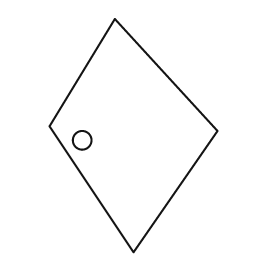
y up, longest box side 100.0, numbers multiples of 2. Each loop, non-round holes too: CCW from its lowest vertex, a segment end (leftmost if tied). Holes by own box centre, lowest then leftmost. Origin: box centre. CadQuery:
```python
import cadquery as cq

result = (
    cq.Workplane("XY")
    .moveTo(0.0, -50.0)
    .lineTo(36.0, 2.0)
    .lineTo(-8.0, 50.0)
    .lineTo(-36.0, 4.0)
    .close()
    .moveTo(-22.0, -2.0)
    .circle(4.0)
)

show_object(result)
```